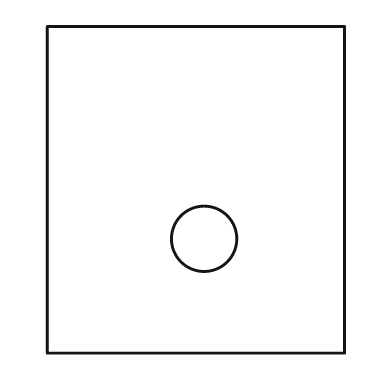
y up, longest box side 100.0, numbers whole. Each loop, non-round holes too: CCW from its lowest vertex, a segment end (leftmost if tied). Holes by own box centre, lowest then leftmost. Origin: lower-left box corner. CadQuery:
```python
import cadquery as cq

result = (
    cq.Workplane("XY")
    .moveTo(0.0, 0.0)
    .lineTo(91.0, 0.0)
    .lineTo(91.0, 100.0)
    .lineTo(0.0, 100.0)
    .close()
    .moveTo(48.0, 35.0)
    .circle(10.0)
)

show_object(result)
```